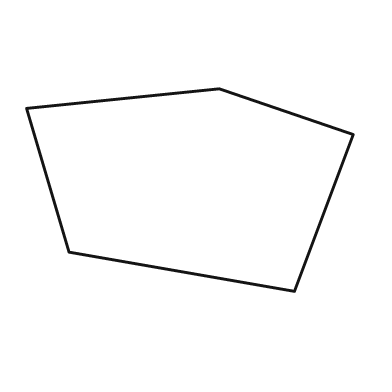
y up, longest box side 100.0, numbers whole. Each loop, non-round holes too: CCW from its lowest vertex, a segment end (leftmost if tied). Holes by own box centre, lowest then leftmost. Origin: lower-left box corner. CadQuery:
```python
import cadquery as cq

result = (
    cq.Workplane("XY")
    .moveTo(82.0, 0.0)
    .lineTo(100.0, 48.0)
    .lineTo(59.0, 62.0)
    .lineTo(0.0, 56.0)
    .lineTo(13.0, 12.0)
    .close()
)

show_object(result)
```